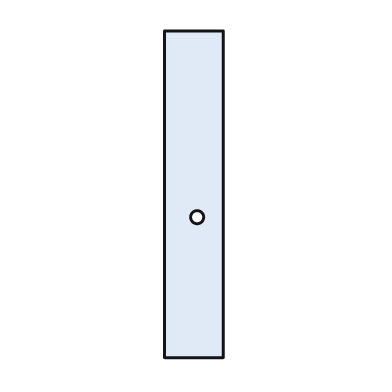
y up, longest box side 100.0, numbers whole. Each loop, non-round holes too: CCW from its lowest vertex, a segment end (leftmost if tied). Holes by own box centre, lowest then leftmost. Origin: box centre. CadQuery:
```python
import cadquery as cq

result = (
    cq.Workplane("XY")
    .moveTo(-9.0, -50.0)
    .lineTo(9.0, -50.0)
    .lineTo(9.0, 50.0)
    .lineTo(-9.0, 50.0)
    .close()
    .moveTo(1.0, -7.0)
    .circle(2.0)
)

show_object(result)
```